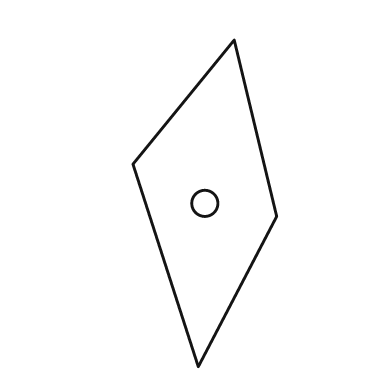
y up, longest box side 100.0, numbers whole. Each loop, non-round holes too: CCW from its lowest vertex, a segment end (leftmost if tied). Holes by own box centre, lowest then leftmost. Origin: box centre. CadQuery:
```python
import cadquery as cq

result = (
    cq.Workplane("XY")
    .moveTo(-2.0, -50.0)
    .lineTo(22.0, -4.0)
    .lineTo(9.0, 50.0)
    .lineTo(-22.0, 12.0)
    .close()
    .moveTo(0.0, 0.0)
    .circle(4.0)
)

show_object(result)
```